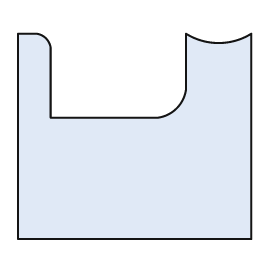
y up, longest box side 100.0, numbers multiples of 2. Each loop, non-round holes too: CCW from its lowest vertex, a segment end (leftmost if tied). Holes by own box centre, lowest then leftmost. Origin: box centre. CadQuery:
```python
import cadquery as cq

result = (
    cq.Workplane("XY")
    .moveTo(-50.0, -44.0)
    .lineTo(50.0, -44.0)
    .lineTo(50.0, 44.0)
    .threePointArc((36.0, 40.0), (22.0, 44.0))
    .lineTo(22.0, 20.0)
    .threePointArc((18.0, 12.0), (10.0, 8.0))
    .lineTo(-36.0, 8.0)
    .lineTo(-36.0, 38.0)
    .threePointArc((-38.0, 42.0), (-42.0, 44.0))
    .lineTo(-50.0, 44.0)
    .close()
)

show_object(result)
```